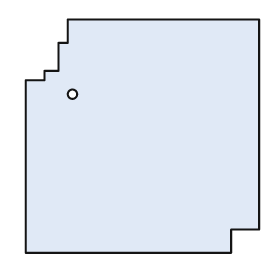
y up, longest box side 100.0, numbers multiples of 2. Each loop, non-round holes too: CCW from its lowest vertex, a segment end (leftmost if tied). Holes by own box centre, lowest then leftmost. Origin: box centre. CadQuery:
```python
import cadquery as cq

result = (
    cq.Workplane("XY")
    .moveTo(-50.0, -50.0)
    .lineTo(38.0, -50.0)
    .lineTo(38.0, -40.0)
    .lineTo(50.0, -40.0)
    .lineTo(50.0, 50.0)
    .lineTo(-32.0, 50.0)
    .lineTo(-32.0, 40.0)
    .lineTo(-36.0, 40.0)
    .lineTo(-36.0, 28.0)
    .lineTo(-42.0, 28.0)
    .lineTo(-42.0, 24.0)
    .lineTo(-50.0, 24.0)
    .close()
    .moveTo(-30.0, 18.0)
    .circle(2.0)
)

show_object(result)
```